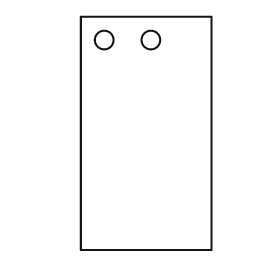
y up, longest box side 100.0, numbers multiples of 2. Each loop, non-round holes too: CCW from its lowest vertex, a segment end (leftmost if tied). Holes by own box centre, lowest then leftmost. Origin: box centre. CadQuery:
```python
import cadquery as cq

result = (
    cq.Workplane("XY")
    .moveTo(-28.0, -50.0)
    .lineTo(28.0, -50.0)
    .lineTo(28.0, 50.0)
    .lineTo(-28.0, 50.0)
    .close()
    .moveTo(-18.0, 40.0)
    .circle(4.0)
    .moveTo(2.0, 40.0)
    .circle(4.0)
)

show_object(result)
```